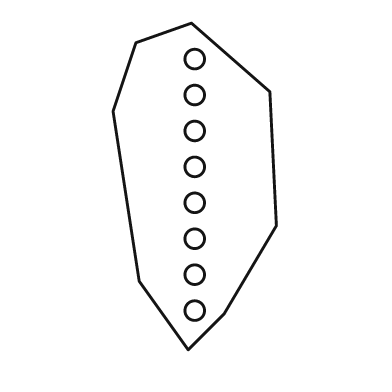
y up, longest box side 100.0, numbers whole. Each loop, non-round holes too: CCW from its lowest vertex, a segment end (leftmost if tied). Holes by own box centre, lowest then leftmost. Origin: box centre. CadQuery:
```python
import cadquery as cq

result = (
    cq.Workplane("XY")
    .moveTo(-2.0, -50.0)
    .lineTo(9.0, -39.0)
    .lineTo(25.0, -12.0)
    .lineTo(23.0, 29.0)
    .lineTo(-1.0, 50.0)
    .lineTo(-18.0, 44.0)
    .lineTo(-25.0, 23.0)
    .lineTo(-17.0, -29.0)
    .close()
    .moveTo(0.0, -38.0)
    .circle(3.0)
    .moveTo(0.0, -27.0)
    .circle(3.0)
    .moveTo(0.0, -16.0)
    .circle(3.0)
    .moveTo(0.0, -5.0)
    .circle(3.0)
    .moveTo(0.0, 6.0)
    .circle(3.0)
    .moveTo(0.0, 17.0)
    .circle(3.0)
    .moveTo(0.0, 28.0)
    .circle(3.0)
    .moveTo(0.0, 39.0)
    .circle(3.0)
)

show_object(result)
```